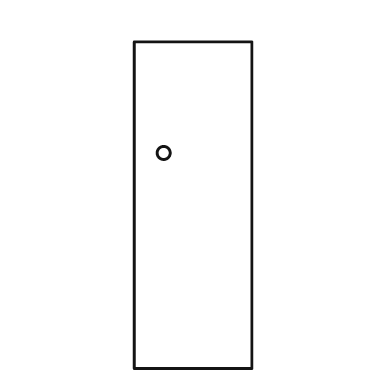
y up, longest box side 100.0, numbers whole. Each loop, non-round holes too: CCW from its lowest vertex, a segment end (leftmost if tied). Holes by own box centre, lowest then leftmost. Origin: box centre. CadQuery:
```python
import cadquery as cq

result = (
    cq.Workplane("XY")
    .moveTo(-18.0, -50.0)
    .lineTo(18.0, -50.0)
    .lineTo(18.0, 50.0)
    .lineTo(-18.0, 50.0)
    .close()
    .moveTo(-9.0, 16.0)
    .circle(2.0)
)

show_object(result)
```